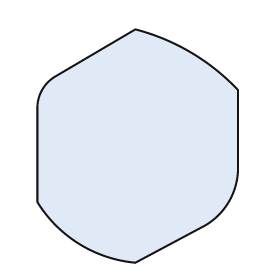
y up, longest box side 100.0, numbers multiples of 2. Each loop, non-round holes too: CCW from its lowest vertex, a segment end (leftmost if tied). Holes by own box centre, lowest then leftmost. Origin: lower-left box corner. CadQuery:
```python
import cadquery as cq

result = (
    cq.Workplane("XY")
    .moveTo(42.0, 0.0)
    .lineTo(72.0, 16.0)
    .threePointArc((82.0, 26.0), (86.0, 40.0))
    .lineTo(86.0, 74.0)
    .threePointArc((66.0, 90.0), (42.0, 100.0))
    .lineTo(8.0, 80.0)
    .threePointArc((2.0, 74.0), (0.0, 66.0))
    .lineTo(0.0, 26.0)
    .threePointArc((18.0, 8.0), (42.0, 0.0))
    .close()
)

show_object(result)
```